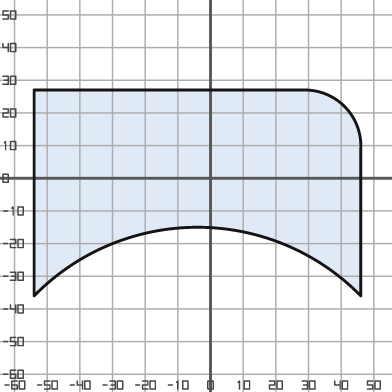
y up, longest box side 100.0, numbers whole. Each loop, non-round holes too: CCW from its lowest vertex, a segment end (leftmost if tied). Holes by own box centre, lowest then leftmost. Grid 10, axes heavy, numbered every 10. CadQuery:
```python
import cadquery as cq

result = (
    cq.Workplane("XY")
    .moveTo(-54.0, -36.0)
    .threePointArc((-4.0, -15.0), (46.0, -36.0))
    .lineTo(46.0, 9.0)
    .threePointArc((41.0, 22.0), (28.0, 27.0))
    .lineTo(-54.0, 27.0)
    .close()
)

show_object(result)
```